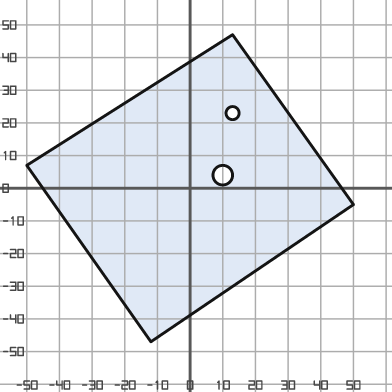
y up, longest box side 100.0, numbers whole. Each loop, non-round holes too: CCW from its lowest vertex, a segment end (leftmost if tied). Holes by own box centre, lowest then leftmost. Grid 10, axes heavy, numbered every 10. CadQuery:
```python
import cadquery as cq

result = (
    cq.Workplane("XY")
    .moveTo(-12.0, -47.0)
    .lineTo(50.0, -5.0)
    .lineTo(13.0, 47.0)
    .lineTo(-50.0, 7.0)
    .close()
    .moveTo(10.0, 4.0)
    .circle(3.0)
    .moveTo(13.0, 23.0)
    .circle(2.0)
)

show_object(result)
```